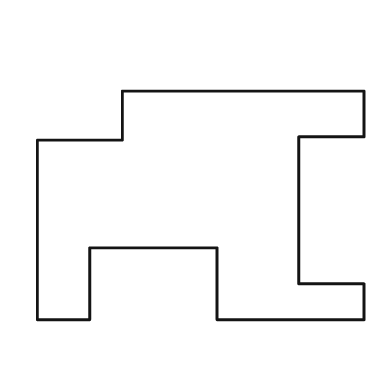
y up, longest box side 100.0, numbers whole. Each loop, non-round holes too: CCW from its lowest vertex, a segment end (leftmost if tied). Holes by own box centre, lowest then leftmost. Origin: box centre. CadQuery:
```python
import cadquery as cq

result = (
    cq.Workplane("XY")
    .moveTo(-50.0, -35.0)
    .lineTo(-34.0, -35.0)
    .lineTo(-34.0, -13.0)
    .lineTo(5.0, -13.0)
    .lineTo(5.0, -35.0)
    .lineTo(50.0, -35.0)
    .lineTo(50.0, -24.0)
    .lineTo(30.0, -24.0)
    .lineTo(30.0, 21.0)
    .lineTo(50.0, 21.0)
    .lineTo(50.0, 35.0)
    .lineTo(-24.0, 35.0)
    .lineTo(-24.0, 20.0)
    .lineTo(-50.0, 20.0)
    .close()
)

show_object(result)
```